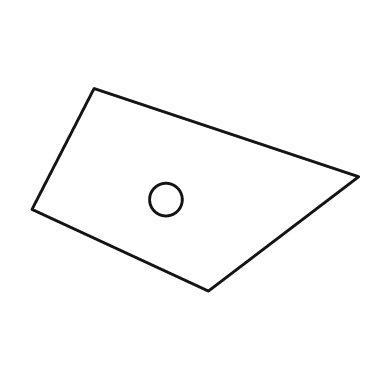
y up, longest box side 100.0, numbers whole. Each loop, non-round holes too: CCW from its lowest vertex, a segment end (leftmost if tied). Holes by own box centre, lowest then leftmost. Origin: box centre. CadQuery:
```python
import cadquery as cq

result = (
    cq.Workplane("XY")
    .moveTo(4.0, -31.0)
    .lineTo(50.0, 4.0)
    .lineTo(-31.0, 31.0)
    .lineTo(-50.0, -6.0)
    .close()
    .moveTo(-9.0, -3.0)
    .circle(5.0)
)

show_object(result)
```